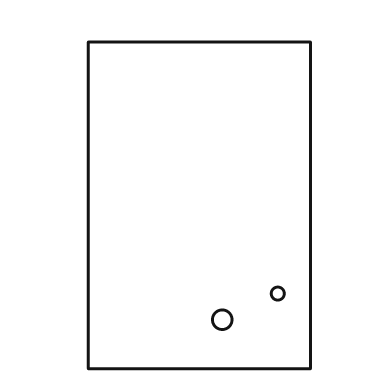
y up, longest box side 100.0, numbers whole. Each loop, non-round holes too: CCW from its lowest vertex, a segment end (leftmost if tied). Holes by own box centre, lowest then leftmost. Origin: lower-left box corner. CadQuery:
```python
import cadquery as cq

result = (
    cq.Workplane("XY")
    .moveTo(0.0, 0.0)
    .lineTo(68.0, 0.0)
    .lineTo(68.0, 100.0)
    .lineTo(0.0, 100.0)
    .close()
    .moveTo(41.0, 15.0)
    .circle(3.0)
    .moveTo(58.0, 23.0)
    .circle(2.0)
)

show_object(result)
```